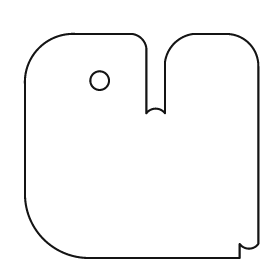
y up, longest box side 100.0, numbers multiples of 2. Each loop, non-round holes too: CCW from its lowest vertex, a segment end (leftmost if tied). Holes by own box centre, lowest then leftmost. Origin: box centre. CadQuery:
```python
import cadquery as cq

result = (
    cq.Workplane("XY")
    .moveTo(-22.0, -48.0)
    .lineTo(42.0, -48.0)
    .lineTo(42.0, -42.0)
    .threePointArc((46.0, -44.0), (50.0, -42.0))
    .lineTo(50.0, 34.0)
    .threePointArc((46.0, 44.0), (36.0, 48.0))
    .lineTo(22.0, 48.0)
    .threePointArc((14.0, 44.0), (10.0, 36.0))
    .lineTo(10.0, 14.0)
    .threePointArc((6.0, 16.0), (2.0, 14.0))
    .lineTo(2.0, 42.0)
    .threePointArc((0.0, 46.0), (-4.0, 48.0))
    .lineTo(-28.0, 48.0)
    .threePointArc((-44.0, 42.0), (-50.0, 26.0))
    .lineTo(-50.0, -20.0)
    .threePointArc((-42.0, -40.0), (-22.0, -48.0))
    .close()
    .moveTo(-18.0, 28.0)
    .circle(4.0)
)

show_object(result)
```